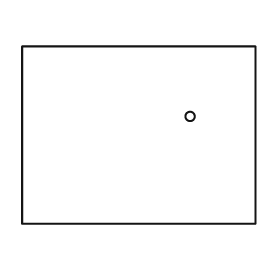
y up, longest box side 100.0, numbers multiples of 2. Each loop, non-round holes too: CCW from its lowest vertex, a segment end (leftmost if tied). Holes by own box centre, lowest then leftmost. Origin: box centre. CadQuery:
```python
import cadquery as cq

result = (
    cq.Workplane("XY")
    .moveTo(-50.0, -38.0)
    .lineTo(50.0, -38.0)
    .lineTo(50.0, 38.0)
    .lineTo(-50.0, 38.0)
    .close()
    .moveTo(22.0, 8.0)
    .circle(2.0)
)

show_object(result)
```